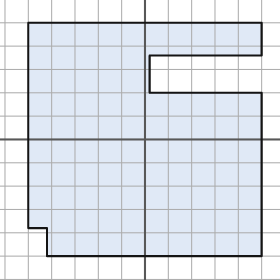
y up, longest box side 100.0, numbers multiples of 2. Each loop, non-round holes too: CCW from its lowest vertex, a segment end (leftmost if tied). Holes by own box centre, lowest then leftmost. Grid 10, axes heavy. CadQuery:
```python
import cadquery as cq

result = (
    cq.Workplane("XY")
    .moveTo(-42.0, -50.0)
    .lineTo(50.0, -50.0)
    .lineTo(50.0, 20.0)
    .lineTo(2.0, 20.0)
    .lineTo(2.0, 36.0)
    .lineTo(50.0, 36.0)
    .lineTo(50.0, 50.0)
    .lineTo(-50.0, 50.0)
    .lineTo(-50.0, -38.0)
    .lineTo(-42.0, -38.0)
    .close()
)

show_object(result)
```